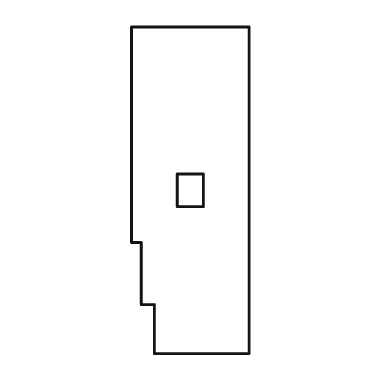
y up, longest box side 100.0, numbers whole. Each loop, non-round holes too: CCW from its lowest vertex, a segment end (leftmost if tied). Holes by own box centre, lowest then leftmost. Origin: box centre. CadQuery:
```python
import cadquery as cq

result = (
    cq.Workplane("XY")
    .moveTo(-11.0, -50.0)
    .lineTo(18.0, -50.0)
    .lineTo(18.0, 50.0)
    .lineTo(-18.0, 50.0)
    .lineTo(-18.0, -16.0)
    .lineTo(-15.0, -16.0)
    .lineTo(-15.0, -35.0)
    .lineTo(-11.0, -35.0)
    .close()
    .moveTo(-4.0, -5.0)
    .lineTo(4.0, -5.0)
    .lineTo(4.0, 5.0)
    .lineTo(-4.0, 5.0)
    .close()
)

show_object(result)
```